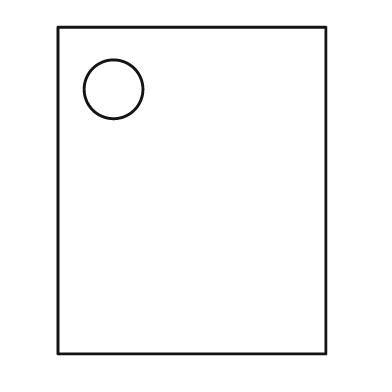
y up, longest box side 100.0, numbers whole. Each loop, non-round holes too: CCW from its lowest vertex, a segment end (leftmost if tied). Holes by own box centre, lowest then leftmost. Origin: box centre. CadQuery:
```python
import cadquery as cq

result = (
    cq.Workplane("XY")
    .moveTo(-41.0, -50.0)
    .lineTo(41.0, -50.0)
    .lineTo(41.0, 50.0)
    .lineTo(-41.0, 50.0)
    .close()
    .moveTo(-24.0, 31.0)
    .circle(9.0)
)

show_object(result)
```